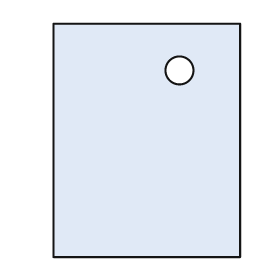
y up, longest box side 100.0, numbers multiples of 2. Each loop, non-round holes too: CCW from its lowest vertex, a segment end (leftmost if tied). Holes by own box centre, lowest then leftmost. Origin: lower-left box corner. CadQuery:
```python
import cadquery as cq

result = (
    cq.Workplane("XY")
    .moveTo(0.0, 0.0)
    .lineTo(80.0, 0.0)
    .lineTo(80.0, 100.0)
    .lineTo(0.0, 100.0)
    .close()
    .moveTo(54.0, 80.0)
    .circle(6.0)
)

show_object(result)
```